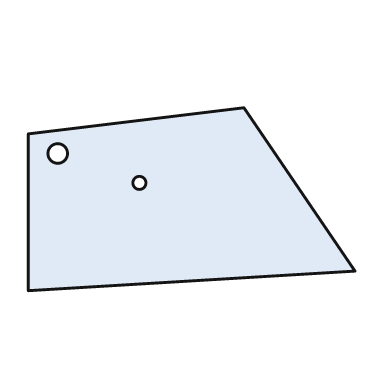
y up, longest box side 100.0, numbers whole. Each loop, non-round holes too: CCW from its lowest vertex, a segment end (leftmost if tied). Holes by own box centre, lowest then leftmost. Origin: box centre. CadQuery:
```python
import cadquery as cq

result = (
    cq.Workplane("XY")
    .moveTo(-50.0, -28.0)
    .lineTo(50.0, -22.0)
    .lineTo(16.0, 28.0)
    .lineTo(-50.0, 20.0)
    .close()
    .moveTo(-16.0, 5.0)
    .circle(2.0)
    .moveTo(-41.0, 14.0)
    .circle(3.0)
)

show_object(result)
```